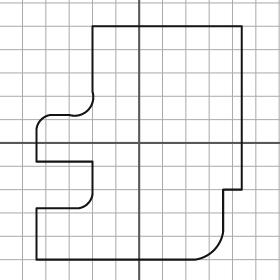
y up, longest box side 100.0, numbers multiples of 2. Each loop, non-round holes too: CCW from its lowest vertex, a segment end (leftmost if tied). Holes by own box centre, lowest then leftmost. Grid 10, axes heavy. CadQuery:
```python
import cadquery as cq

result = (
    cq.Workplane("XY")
    .moveTo(-44.0, -50.0)
    .lineTo(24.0, -50.0)
    .threePointArc((32.0, -46.0), (36.0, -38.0))
    .lineTo(36.0, -20.0)
    .lineTo(44.0, -20.0)
    .lineTo(44.0, 50.0)
    .lineTo(-20.0, 50.0)
    .lineTo(-20.0, 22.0)
    .threePointArc((-22.0, 14.0), (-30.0, 12.0))
    .lineTo(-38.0, 12.0)
    .threePointArc((-42.0, 10.0), (-44.0, 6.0))
    .lineTo(-44.0, -8.0)
    .lineTo(-20.0, -8.0)
    .lineTo(-20.0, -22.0)
    .threePointArc((-22.0, -26.0), (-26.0, -28.0))
    .lineTo(-44.0, -28.0)
    .close()
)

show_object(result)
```